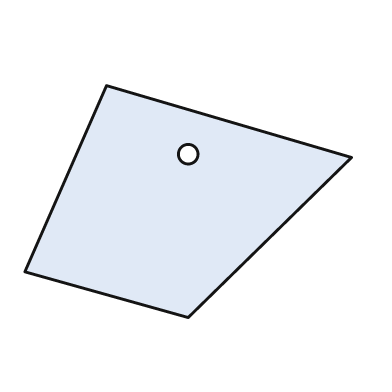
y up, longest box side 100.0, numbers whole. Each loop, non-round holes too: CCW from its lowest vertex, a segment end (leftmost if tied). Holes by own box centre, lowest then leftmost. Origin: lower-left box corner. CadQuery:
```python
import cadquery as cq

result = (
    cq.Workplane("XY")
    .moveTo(50.0, 0.0)
    .lineTo(100.0, 49.0)
    .lineTo(25.0, 71.0)
    .lineTo(0.0, 14.0)
    .close()
    .moveTo(50.0, 50.0)
    .circle(3.0)
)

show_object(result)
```